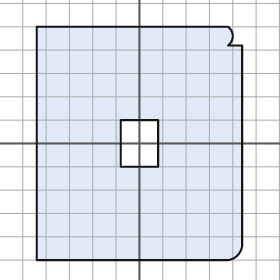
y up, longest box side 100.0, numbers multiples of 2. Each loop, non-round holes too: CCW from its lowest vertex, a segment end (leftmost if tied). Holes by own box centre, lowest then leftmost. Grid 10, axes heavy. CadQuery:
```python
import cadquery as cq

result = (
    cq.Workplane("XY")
    .moveTo(-44.0, -50.0)
    .lineTo(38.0, -50.0)
    .threePointArc((42.0, -48.0), (44.0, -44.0))
    .lineTo(44.0, 42.0)
    .lineTo(38.0, 42.0)
    .threePointArc((40.0, 46.0), (38.0, 50.0))
    .lineTo(-44.0, 50.0)
    .close()
    .moveTo(-8.0, -10.0)
    .lineTo(8.0, -10.0)
    .lineTo(8.0, 10.0)
    .lineTo(-8.0, 10.0)
    .close()
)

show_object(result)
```